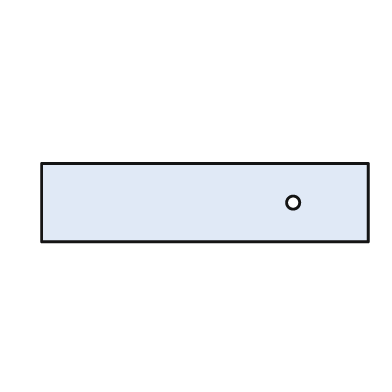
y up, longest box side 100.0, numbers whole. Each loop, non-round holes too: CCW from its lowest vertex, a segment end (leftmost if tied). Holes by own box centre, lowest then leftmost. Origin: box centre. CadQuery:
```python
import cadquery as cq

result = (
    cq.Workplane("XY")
    .moveTo(-50.0, -12.0)
    .lineTo(50.0, -12.0)
    .lineTo(50.0, 12.0)
    .lineTo(-50.0, 12.0)
    .close()
    .moveTo(27.0, 0.0)
    .circle(2.0)
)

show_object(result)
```